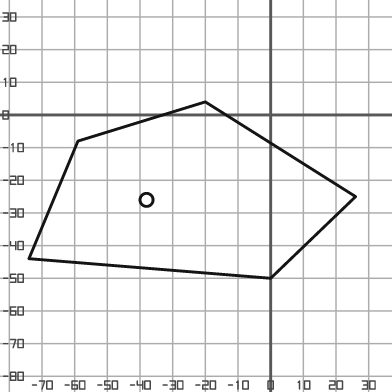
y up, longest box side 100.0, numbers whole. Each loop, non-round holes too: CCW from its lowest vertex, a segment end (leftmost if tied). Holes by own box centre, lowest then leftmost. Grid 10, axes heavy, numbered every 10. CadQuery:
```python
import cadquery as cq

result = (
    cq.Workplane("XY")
    .moveTo(0.0, -50.0)
    .lineTo(26.0, -25.0)
    .lineTo(-20.0, 4.0)
    .lineTo(-59.0, -8.0)
    .lineTo(-74.0, -44.0)
    .close()
    .moveTo(-38.0, -26.0)
    .circle(2.0)
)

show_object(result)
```